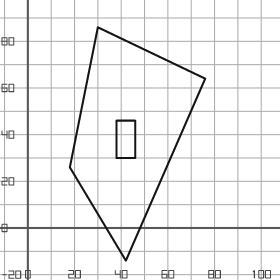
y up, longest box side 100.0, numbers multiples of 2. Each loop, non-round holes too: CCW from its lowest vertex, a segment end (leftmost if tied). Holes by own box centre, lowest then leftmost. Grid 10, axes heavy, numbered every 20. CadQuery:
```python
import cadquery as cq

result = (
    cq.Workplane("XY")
    .moveTo(42.0, -14.0)
    .lineTo(76.0, 64.0)
    .lineTo(30.0, 86.0)
    .lineTo(18.0, 26.0)
    .close()
    .moveTo(38.0, 30.0)
    .lineTo(46.0, 30.0)
    .lineTo(46.0, 46.0)
    .lineTo(38.0, 46.0)
    .close()
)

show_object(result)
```